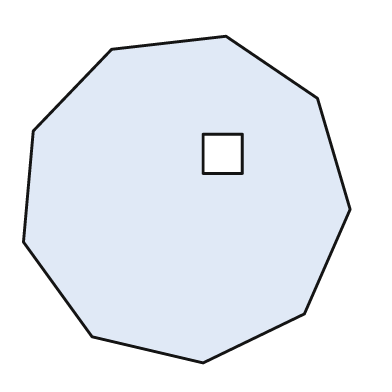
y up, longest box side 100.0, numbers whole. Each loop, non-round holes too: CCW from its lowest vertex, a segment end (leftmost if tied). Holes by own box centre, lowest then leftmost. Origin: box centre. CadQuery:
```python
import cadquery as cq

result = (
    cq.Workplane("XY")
    .moveTo(5.0, -50.0)
    .lineTo(36.0, -35.0)
    .lineTo(50.0, -3.0)
    .lineTo(40.0, 31.0)
    .lineTo(12.0, 50.0)
    .lineTo(-23.0, 46.0)
    .lineTo(-47.0, 21.0)
    .lineTo(-50.0, -13.0)
    .lineTo(-29.0, -42.0)
    .close()
    .moveTo(5.0, 8.0)
    .lineTo(17.0, 8.0)
    .lineTo(17.0, 20.0)
    .lineTo(5.0, 20.0)
    .close()
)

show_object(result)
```